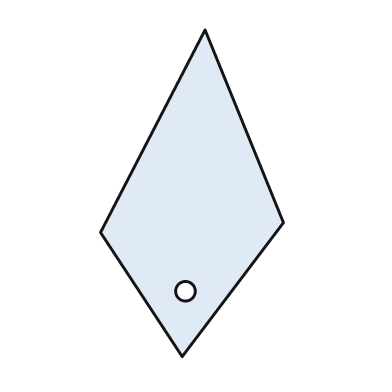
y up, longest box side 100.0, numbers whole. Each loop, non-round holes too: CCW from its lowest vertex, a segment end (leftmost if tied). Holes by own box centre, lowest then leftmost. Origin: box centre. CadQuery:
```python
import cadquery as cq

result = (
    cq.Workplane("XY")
    .moveTo(-3.0, -50.0)
    .lineTo(28.0, -9.0)
    .lineTo(4.0, 50.0)
    .lineTo(-28.0, -12.0)
    .close()
    .moveTo(-2.0, -30.0)
    .circle(3.0)
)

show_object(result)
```